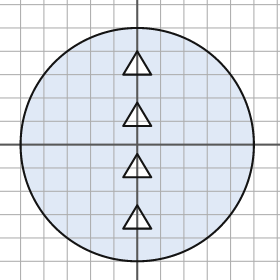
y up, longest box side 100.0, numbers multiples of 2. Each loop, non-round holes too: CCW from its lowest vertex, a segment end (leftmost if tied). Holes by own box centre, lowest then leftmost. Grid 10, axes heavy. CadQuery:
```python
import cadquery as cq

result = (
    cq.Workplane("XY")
    .moveTo(0.0, 0.0)
    .circle(50.0)
    .moveTo(-6.0, -36.0)
    .lineTo(6.0, -36.0)
    .lineTo(0.0, -26.0)
    .close()
    .moveTo(-6.0, -14.0)
    .lineTo(6.0, -14.0)
    .lineTo(0.0, -4.0)
    .close()
    .moveTo(-6.0, 8.0)
    .lineTo(6.0, 8.0)
    .lineTo(0.0, 18.0)
    .close()
    .moveTo(-6.0, 30.0)
    .lineTo(6.0, 30.0)
    .lineTo(0.0, 40.0)
    .close()
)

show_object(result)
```